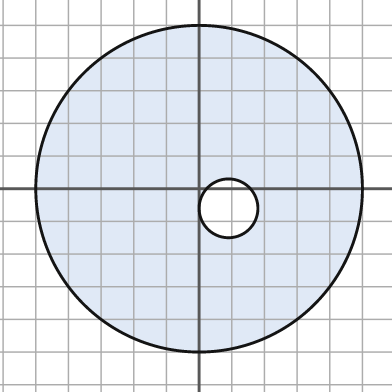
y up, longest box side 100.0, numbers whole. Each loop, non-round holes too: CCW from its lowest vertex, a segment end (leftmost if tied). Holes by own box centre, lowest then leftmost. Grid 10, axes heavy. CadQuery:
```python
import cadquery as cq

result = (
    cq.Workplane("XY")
    .moveTo(0.0, 0.0)
    .circle(50.0)
    .moveTo(9.0, -6.0)
    .circle(9.0)
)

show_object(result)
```